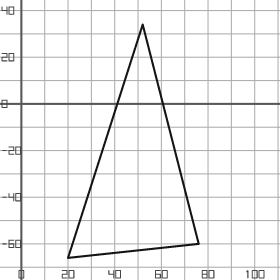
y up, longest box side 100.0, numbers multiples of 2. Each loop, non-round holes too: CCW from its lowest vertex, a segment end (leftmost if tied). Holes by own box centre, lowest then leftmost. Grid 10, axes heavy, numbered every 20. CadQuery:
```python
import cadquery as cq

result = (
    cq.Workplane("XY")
    .moveTo(20.0, -66.0)
    .lineTo(76.0, -60.0)
    .lineTo(52.0, 34.0)
    .close()
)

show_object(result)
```